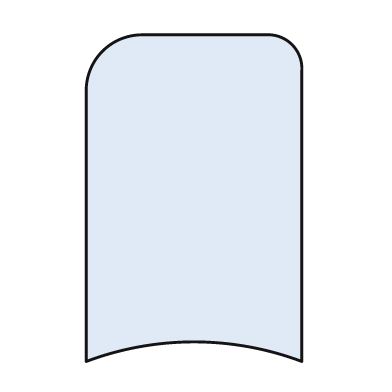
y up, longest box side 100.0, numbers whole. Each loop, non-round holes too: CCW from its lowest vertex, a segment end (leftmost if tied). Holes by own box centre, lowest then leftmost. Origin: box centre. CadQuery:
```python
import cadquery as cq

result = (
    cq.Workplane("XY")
    .moveTo(-33.0, -50.0)
    .threePointArc((0.0, -44.0), (33.0, -50.0))
    .lineTo(33.0, 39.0)
    .threePointArc((30.0, 47.0), (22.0, 50.0))
    .lineTo(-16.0, 50.0)
    .threePointArc((-28.0, 45.0), (-33.0, 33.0))
    .close()
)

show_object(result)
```